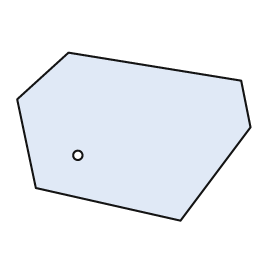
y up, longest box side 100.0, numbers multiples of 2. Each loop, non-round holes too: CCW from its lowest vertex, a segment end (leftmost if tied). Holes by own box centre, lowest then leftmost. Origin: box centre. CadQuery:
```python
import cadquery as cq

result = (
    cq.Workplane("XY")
    .moveTo(20.0, -36.0)
    .lineTo(50.0, 4.0)
    .lineTo(46.0, 24.0)
    .lineTo(-28.0, 36.0)
    .lineTo(-50.0, 16.0)
    .lineTo(-42.0, -22.0)
    .close()
    .moveTo(-24.0, -8.0)
    .circle(2.0)
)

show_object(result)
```